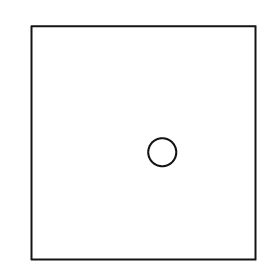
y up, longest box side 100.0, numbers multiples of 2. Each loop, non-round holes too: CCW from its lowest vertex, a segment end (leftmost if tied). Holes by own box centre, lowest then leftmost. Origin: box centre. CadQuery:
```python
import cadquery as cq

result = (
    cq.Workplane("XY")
    .moveTo(-48.0, -50.0)
    .lineTo(48.0, -50.0)
    .lineTo(48.0, 50.0)
    .lineTo(-48.0, 50.0)
    .close()
    .moveTo(8.0, -4.0)
    .circle(6.0)
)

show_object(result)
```